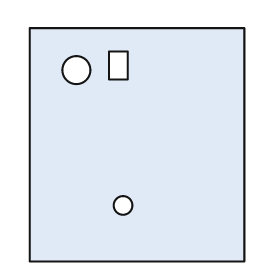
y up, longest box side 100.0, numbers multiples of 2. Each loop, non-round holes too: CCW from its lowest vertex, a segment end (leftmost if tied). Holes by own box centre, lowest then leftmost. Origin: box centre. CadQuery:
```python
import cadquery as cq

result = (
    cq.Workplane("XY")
    .moveTo(-46.0, -50.0)
    .lineTo(46.0, -50.0)
    .lineTo(46.0, 50.0)
    .lineTo(-46.0, 50.0)
    .close()
    .moveTo(-6.0, -26.0)
    .circle(4.0)
    .moveTo(-26.0, 32.0)
    .circle(6.0)
    .moveTo(-12.0, 28.0)
    .lineTo(-4.0, 28.0)
    .lineTo(-4.0, 40.0)
    .lineTo(-12.0, 40.0)
    .close()
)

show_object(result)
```